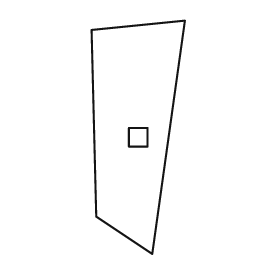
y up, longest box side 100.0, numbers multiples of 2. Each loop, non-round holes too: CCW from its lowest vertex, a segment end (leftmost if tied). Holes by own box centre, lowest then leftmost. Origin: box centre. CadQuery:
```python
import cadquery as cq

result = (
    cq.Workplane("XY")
    .moveTo(6.0, -50.0)
    .lineTo(20.0, 50.0)
    .lineTo(-20.0, 46.0)
    .lineTo(-18.0, -34.0)
    .close()
    .moveTo(-4.0, -4.0)
    .lineTo(4.0, -4.0)
    .lineTo(4.0, 4.0)
    .lineTo(-4.0, 4.0)
    .close()
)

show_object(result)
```